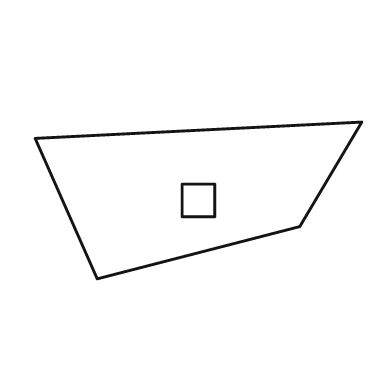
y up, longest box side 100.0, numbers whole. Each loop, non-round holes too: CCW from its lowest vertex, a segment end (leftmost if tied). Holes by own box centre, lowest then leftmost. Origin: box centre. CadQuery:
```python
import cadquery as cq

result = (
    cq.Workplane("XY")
    .moveTo(-31.0, -24.0)
    .lineTo(31.0, -8.0)
    .lineTo(50.0, 24.0)
    .lineTo(-50.0, 19.0)
    .close()
    .moveTo(-5.0, -5.0)
    .lineTo(5.0, -5.0)
    .lineTo(5.0, 5.0)
    .lineTo(-5.0, 5.0)
    .close()
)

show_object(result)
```